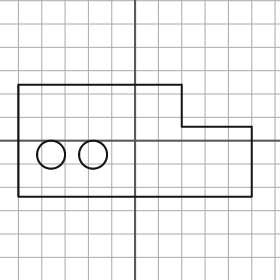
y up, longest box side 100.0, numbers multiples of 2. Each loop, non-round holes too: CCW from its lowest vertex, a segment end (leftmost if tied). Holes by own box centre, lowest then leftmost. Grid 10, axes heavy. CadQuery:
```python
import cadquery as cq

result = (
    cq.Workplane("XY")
    .moveTo(-50.0, -24.0)
    .lineTo(50.0, -24.0)
    .lineTo(50.0, 6.0)
    .lineTo(20.0, 6.0)
    .lineTo(20.0, 24.0)
    .lineTo(-50.0, 24.0)
    .close()
    .moveTo(-36.0, -6.0)
    .circle(6.0)
    .moveTo(-18.0, -6.0)
    .circle(6.0)
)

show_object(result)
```